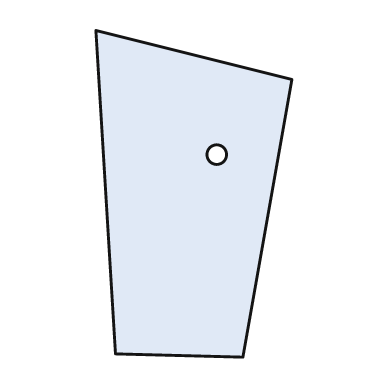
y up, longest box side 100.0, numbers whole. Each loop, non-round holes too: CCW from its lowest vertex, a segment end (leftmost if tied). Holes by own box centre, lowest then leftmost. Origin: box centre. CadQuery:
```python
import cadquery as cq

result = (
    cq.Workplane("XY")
    .moveTo(15.0, -50.0)
    .lineTo(30.0, 35.0)
    .lineTo(-30.0, 50.0)
    .lineTo(-24.0, -49.0)
    .close()
    .moveTo(7.0, 12.0)
    .circle(3.0)
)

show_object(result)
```